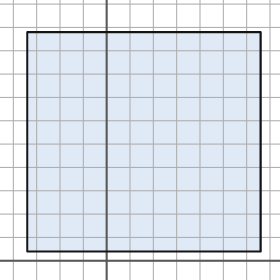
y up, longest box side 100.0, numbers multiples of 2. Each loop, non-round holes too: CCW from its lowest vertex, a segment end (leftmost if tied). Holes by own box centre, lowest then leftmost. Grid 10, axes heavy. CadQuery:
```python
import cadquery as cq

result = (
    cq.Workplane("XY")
    .moveTo(-34.0, 4.0)
    .lineTo(66.0, 4.0)
    .lineTo(66.0, 98.0)
    .lineTo(-34.0, 98.0)
    .close()
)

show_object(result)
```